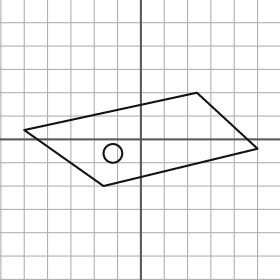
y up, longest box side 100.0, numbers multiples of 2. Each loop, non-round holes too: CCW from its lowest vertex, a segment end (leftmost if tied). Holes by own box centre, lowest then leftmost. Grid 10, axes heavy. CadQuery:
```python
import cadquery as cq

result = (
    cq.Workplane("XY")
    .moveTo(-16.0, -20.0)
    .lineTo(50.0, -4.0)
    .lineTo(24.0, 20.0)
    .lineTo(-50.0, 4.0)
    .close()
    .moveTo(-12.0, -6.0)
    .circle(4.0)
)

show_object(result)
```